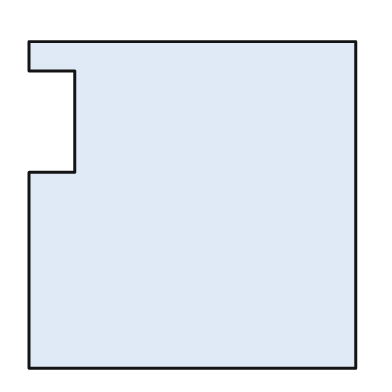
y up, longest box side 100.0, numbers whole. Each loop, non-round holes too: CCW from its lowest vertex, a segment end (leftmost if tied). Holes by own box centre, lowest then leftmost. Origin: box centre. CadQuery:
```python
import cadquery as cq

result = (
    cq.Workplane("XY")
    .moveTo(-50.0, -50.0)
    .lineTo(50.0, -50.0)
    .lineTo(50.0, 50.0)
    .lineTo(-50.0, 50.0)
    .lineTo(-50.0, 41.0)
    .lineTo(-36.0, 41.0)
    .lineTo(-36.0, 10.0)
    .lineTo(-50.0, 10.0)
    .close()
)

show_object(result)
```